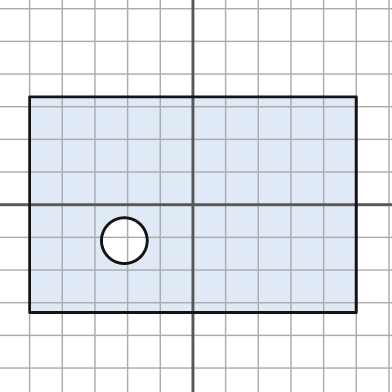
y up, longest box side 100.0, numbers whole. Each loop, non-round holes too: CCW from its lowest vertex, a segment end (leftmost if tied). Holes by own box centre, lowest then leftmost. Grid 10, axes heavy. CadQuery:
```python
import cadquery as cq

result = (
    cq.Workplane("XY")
    .moveTo(-50.0, -33.0)
    .lineTo(50.0, -33.0)
    .lineTo(50.0, 33.0)
    .lineTo(-50.0, 33.0)
    .close()
    .moveTo(-21.0, -11.0)
    .circle(7.0)
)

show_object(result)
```